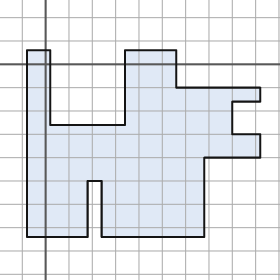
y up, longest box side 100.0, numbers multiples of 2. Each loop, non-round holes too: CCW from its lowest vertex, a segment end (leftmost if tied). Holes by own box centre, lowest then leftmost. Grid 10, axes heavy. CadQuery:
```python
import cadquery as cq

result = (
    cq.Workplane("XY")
    .moveTo(-8.0, -74.0)
    .lineTo(18.0, -74.0)
    .lineTo(18.0, -50.0)
    .lineTo(24.0, -50.0)
    .lineTo(24.0, -74.0)
    .lineTo(68.0, -74.0)
    .lineTo(68.0, -40.0)
    .lineTo(92.0, -40.0)
    .lineTo(92.0, -30.0)
    .lineTo(80.0, -30.0)
    .lineTo(80.0, -16.0)
    .lineTo(92.0, -16.0)
    .lineTo(92.0, -10.0)
    .lineTo(56.0, -10.0)
    .lineTo(56.0, 6.0)
    .lineTo(34.0, 6.0)
    .lineTo(34.0, -26.0)
    .lineTo(2.0, -26.0)
    .lineTo(2.0, 6.0)
    .lineTo(-8.0, 6.0)
    .close()
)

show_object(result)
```